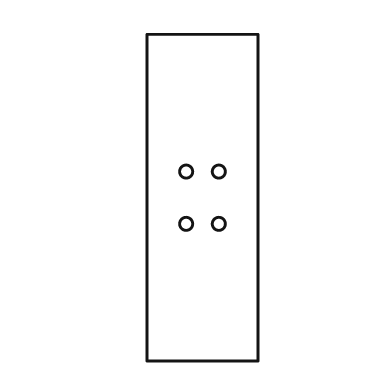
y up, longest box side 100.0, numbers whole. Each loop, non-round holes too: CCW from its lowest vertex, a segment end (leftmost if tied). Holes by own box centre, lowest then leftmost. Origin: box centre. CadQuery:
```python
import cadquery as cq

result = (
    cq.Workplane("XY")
    .moveTo(-17.0, -50.0)
    .lineTo(17.0, -50.0)
    .lineTo(17.0, 50.0)
    .lineTo(-17.0, 50.0)
    .close()
    .moveTo(-5.0, -8.0)
    .circle(2.0)
    .moveTo(5.0, -8.0)
    .circle(2.0)
    .moveTo(-5.0, 8.0)
    .circle(2.0)
    .moveTo(5.0, 8.0)
    .circle(2.0)
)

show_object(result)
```